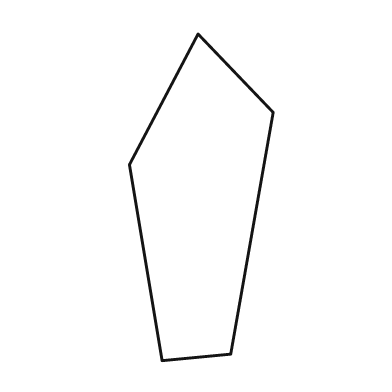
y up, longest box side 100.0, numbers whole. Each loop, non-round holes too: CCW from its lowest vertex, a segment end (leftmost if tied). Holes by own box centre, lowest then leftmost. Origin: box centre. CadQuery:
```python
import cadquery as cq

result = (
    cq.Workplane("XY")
    .moveTo(-12.0, -50.0)
    .lineTo(9.0, -48.0)
    .lineTo(22.0, 26.0)
    .lineTo(-1.0, 50.0)
    .lineTo(-22.0, 10.0)
    .close()
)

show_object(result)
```